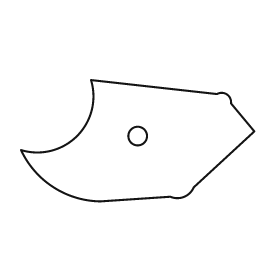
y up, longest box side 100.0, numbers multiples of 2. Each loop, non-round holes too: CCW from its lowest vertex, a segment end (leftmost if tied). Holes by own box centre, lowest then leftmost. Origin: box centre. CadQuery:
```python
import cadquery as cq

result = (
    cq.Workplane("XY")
    .moveTo(-16.0, -26.0)
    .lineTo(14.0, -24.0)
    .threePointArc((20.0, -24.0), (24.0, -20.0))
    .lineTo(50.0, 4.0)
    .lineTo(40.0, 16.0)
    .threePointArc((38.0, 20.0), (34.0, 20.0))
    .lineTo(-20.0, 26.0)
    .threePointArc((-26.0, 2.0), (-50.0, -4.0))
    .threePointArc((-36.0, -20.0), (-16.0, -26.0))
    .close()
    .moveTo(0.0, 2.0)
    .circle(4.0)
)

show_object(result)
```